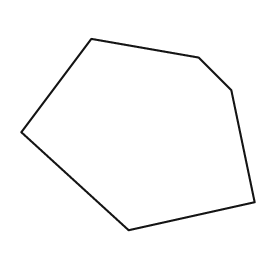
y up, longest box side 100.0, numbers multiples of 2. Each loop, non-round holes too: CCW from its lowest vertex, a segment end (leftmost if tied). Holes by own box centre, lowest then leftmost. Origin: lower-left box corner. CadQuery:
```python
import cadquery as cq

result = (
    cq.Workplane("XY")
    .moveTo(46.0, 0.0)
    .lineTo(100.0, 12.0)
    .lineTo(90.0, 60.0)
    .lineTo(76.0, 74.0)
    .lineTo(30.0, 82.0)
    .lineTo(0.0, 42.0)
    .close()
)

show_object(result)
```